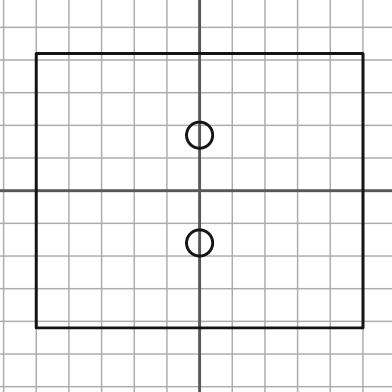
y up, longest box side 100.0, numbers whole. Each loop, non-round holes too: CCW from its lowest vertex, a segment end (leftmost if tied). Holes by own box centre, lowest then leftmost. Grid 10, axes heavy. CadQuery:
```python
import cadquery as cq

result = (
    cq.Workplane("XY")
    .moveTo(-50.0, -42.0)
    .lineTo(50.0, -42.0)
    .lineTo(50.0, 42.0)
    .lineTo(-50.0, 42.0)
    .close()
    .moveTo(0.0, -16.0)
    .circle(4.0)
    .moveTo(0.0, 17.0)
    .circle(4.0)
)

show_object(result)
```